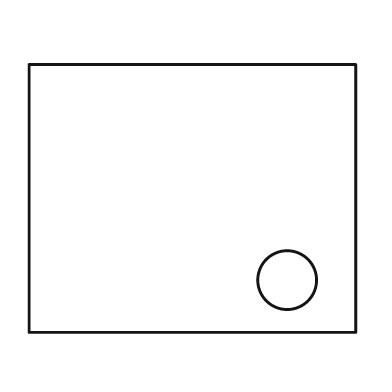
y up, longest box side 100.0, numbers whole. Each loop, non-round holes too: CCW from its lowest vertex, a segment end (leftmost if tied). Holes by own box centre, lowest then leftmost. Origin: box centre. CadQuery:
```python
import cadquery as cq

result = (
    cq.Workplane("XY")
    .moveTo(-50.0, -41.0)
    .lineTo(50.0, -41.0)
    .lineTo(50.0, 41.0)
    .lineTo(-50.0, 41.0)
    .close()
    .moveTo(29.0, -25.0)
    .circle(9.0)
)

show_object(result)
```